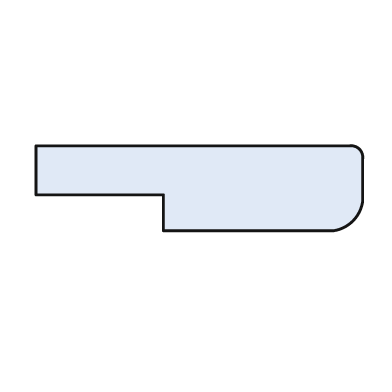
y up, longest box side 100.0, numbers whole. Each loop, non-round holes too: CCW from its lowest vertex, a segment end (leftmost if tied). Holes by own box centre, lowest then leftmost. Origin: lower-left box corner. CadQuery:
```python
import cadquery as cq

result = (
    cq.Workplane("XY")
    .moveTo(39.0, 0.0)
    .lineTo(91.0, 0.0)
    .threePointArc((97.0, 3.0), (100.0, 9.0))
    .lineTo(100.0, 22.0)
    .threePointArc((99.0, 25.0), (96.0, 26.0))
    .lineTo(0.0, 26.0)
    .lineTo(0.0, 11.0)
    .lineTo(39.0, 11.0)
    .close()
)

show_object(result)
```